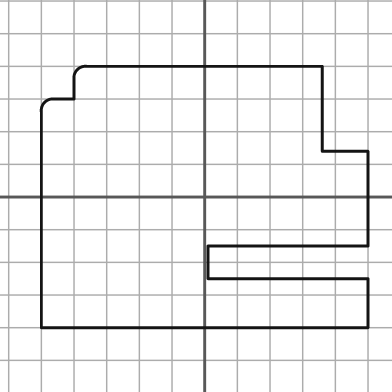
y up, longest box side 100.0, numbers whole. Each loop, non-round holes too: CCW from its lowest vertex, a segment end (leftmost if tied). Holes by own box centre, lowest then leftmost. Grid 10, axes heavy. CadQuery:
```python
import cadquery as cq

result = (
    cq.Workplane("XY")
    .moveTo(-50.0, -40.0)
    .lineTo(50.0, -40.0)
    .lineTo(50.0, -25.0)
    .lineTo(1.0, -25.0)
    .lineTo(1.0, -15.0)
    .lineTo(50.0, -15.0)
    .lineTo(50.0, 14.0)
    .lineTo(36.0, 14.0)
    .lineTo(36.0, 40.0)
    .lineTo(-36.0, 40.0)
    .threePointArc((-39.0, 39.0), (-40.0, 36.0))
    .lineTo(-40.0, 30.0)
    .lineTo(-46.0, 30.0)
    .threePointArc((-49.0, 29.0), (-50.0, 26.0))
    .close()
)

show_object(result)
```